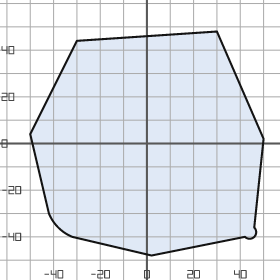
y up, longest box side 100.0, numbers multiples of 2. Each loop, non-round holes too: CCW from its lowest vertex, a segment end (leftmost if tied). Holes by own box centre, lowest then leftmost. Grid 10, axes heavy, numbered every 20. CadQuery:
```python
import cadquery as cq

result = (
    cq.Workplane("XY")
    .moveTo(2.0, -48.0)
    .lineTo(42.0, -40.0)
    .threePointArc((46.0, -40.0), (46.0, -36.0))
    .lineTo(50.0, 2.0)
    .lineTo(30.0, 48.0)
    .lineTo(-30.0, 44.0)
    .lineTo(-50.0, 4.0)
    .lineTo(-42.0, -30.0)
    .threePointArc((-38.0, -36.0), (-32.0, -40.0))
    .close()
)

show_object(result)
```